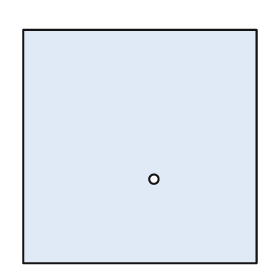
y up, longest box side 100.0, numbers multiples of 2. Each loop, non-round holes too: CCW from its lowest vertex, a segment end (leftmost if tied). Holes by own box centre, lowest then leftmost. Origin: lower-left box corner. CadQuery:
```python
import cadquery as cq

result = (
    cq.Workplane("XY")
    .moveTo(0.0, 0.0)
    .lineTo(100.0, 0.0)
    .lineTo(100.0, 100.0)
    .lineTo(0.0, 100.0)
    .close()
    .moveTo(56.0, 36.0)
    .circle(2.0)
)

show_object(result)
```